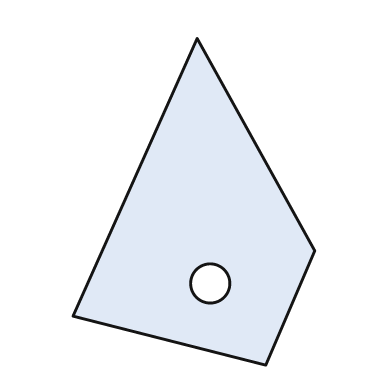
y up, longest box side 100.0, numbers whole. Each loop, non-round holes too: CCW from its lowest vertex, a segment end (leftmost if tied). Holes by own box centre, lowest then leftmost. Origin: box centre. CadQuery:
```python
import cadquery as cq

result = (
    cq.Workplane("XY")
    .moveTo(22.0, -50.0)
    .lineTo(37.0, -15.0)
    .lineTo(1.0, 50.0)
    .lineTo(-37.0, -35.0)
    .close()
    .moveTo(5.0, -25.0)
    .circle(6.0)
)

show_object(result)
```